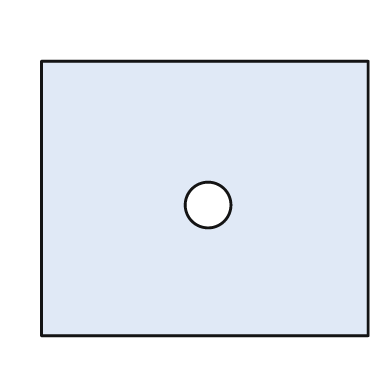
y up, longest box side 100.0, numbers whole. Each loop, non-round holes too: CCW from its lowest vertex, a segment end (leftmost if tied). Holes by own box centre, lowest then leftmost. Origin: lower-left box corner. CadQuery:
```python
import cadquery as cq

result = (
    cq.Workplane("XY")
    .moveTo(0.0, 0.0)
    .lineTo(100.0, 0.0)
    .lineTo(100.0, 84.0)
    .lineTo(0.0, 84.0)
    .close()
    .moveTo(51.0, 40.0)
    .circle(7.0)
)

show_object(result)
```